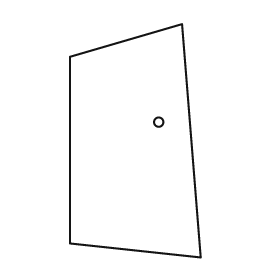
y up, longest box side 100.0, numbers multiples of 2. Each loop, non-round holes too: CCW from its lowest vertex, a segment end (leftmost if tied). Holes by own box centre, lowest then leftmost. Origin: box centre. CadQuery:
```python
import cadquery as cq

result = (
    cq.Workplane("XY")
    .moveTo(28.0, -50.0)
    .lineTo(20.0, 50.0)
    .lineTo(-28.0, 36.0)
    .lineTo(-28.0, -44.0)
    .close()
    .moveTo(10.0, 8.0)
    .circle(2.0)
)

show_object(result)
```